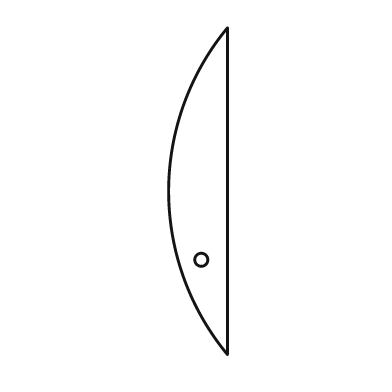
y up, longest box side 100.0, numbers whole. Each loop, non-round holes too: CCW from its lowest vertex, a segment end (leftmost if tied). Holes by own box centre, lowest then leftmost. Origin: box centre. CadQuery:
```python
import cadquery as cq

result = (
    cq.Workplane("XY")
    .moveTo(9.0, -50.0)
    .lineTo(9.0, 50.0)
    .threePointArc((-9.0, 0.0), (9.0, -50.0))
    .close()
    .moveTo(1.0, -21.0)
    .circle(2.0)
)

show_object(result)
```